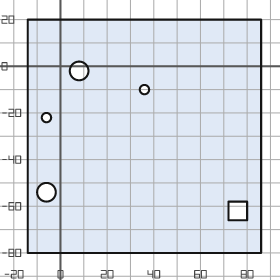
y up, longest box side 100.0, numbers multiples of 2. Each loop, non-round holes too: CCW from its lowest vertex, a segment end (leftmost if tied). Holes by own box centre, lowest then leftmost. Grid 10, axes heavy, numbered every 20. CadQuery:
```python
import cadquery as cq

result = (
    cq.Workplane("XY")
    .moveTo(-14.0, -80.0)
    .lineTo(86.0, -80.0)
    .lineTo(86.0, 20.0)
    .lineTo(-14.0, 20.0)
    .close()
    .moveTo(72.0, -66.0)
    .lineTo(80.0, -66.0)
    .lineTo(80.0, -58.0)
    .lineTo(72.0, -58.0)
    .close()
    .moveTo(-6.0, -54.0)
    .circle(4.0)
    .moveTo(-6.0, -22.0)
    .circle(2.0)
    .moveTo(36.0, -10.0)
    .circle(2.0)
    .moveTo(8.0, -2.0)
    .circle(4.0)
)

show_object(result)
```